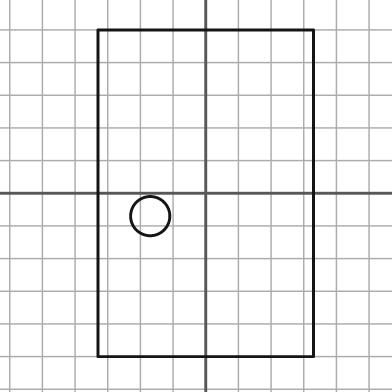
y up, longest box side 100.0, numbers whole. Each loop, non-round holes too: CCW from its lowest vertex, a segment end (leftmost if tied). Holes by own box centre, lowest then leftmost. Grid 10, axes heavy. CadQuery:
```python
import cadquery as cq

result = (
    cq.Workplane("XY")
    .moveTo(-33.0, -50.0)
    .lineTo(33.0, -50.0)
    .lineTo(33.0, 50.0)
    .lineTo(-33.0, 50.0)
    .close()
    .moveTo(-17.0, -7.0)
    .circle(6.0)
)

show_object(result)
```